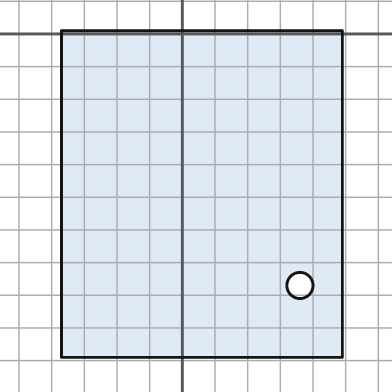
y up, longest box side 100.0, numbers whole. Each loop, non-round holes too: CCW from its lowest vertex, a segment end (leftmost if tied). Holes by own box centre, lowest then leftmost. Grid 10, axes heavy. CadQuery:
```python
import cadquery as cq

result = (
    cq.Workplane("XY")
    .moveTo(-37.0, -99.0)
    .lineTo(49.0, -99.0)
    .lineTo(49.0, 1.0)
    .lineTo(-37.0, 1.0)
    .close()
    .moveTo(36.0, -77.0)
    .circle(4.0)
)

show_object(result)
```